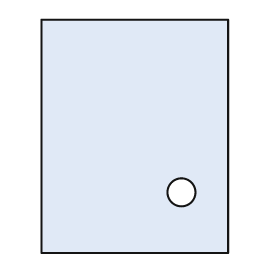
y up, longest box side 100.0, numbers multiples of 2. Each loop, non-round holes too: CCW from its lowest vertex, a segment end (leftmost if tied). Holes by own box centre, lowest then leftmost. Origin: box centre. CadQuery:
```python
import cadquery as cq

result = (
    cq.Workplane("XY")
    .moveTo(-40.0, -50.0)
    .lineTo(40.0, -50.0)
    .lineTo(40.0, 50.0)
    .lineTo(-40.0, 50.0)
    .close()
    .moveTo(20.0, -24.0)
    .circle(6.0)
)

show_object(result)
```